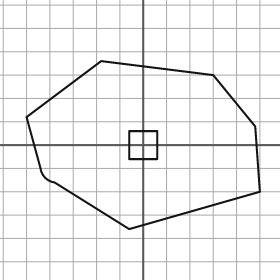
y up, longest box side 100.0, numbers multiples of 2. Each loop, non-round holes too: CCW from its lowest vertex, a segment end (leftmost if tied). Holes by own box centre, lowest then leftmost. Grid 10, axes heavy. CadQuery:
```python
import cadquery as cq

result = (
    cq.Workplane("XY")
    .moveTo(-6.0, -36.0)
    .lineTo(50.0, -20.0)
    .lineTo(48.0, 8.0)
    .lineTo(30.0, 30.0)
    .lineTo(-18.0, 36.0)
    .lineTo(-50.0, 12.0)
    .lineTo(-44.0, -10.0)
    .threePointArc((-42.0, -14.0), (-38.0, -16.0))
    .close()
    .moveTo(-6.0, -6.0)
    .lineTo(6.0, -6.0)
    .lineTo(6.0, 6.0)
    .lineTo(-6.0, 6.0)
    .close()
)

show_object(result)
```